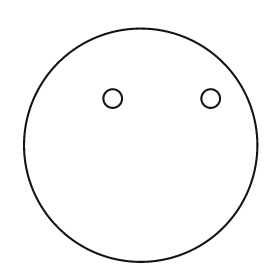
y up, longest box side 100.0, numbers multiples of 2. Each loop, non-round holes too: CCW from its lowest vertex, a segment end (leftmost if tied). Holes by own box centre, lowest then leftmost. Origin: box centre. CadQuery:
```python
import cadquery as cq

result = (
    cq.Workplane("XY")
    .moveTo(0.0, 0.0)
    .circle(50.0)
    .moveTo(-12.0, 20.0)
    .circle(4.0)
    .moveTo(30.0, 20.0)
    .circle(4.0)
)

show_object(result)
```